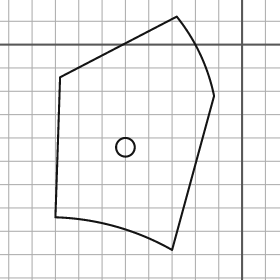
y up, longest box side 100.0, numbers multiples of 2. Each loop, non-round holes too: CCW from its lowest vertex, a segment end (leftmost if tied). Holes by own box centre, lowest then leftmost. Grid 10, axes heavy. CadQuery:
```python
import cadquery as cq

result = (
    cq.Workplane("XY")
    .moveTo(-30.0, -88.0)
    .lineTo(-12.0, -22.0)
    .threePointArc((-18.0, -4.0), (-28.0, 12.0))
    .lineTo(-78.0, -14.0)
    .lineTo(-80.0, -74.0)
    .threePointArc((-54.0, -78.0), (-30.0, -88.0))
    .close()
    .moveTo(-50.0, -44.0)
    .circle(4.0)
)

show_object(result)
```